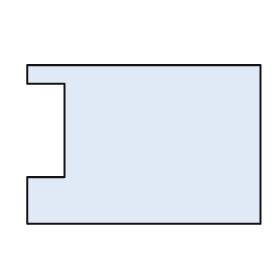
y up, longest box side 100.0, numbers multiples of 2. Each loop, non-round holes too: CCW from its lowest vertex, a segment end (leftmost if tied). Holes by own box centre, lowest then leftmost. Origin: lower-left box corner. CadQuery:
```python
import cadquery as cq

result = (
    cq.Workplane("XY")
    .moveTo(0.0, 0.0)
    .lineTo(100.0, 0.0)
    .lineTo(100.0, 68.0)
    .lineTo(0.0, 68.0)
    .lineTo(0.0, 60.0)
    .lineTo(16.0, 60.0)
    .lineTo(16.0, 20.0)
    .lineTo(0.0, 20.0)
    .close()
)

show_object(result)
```